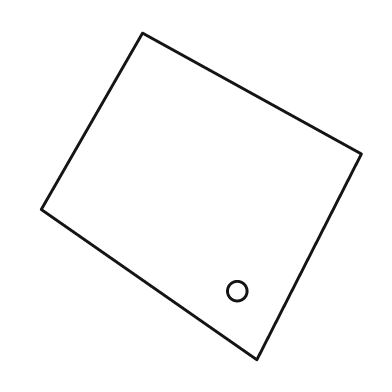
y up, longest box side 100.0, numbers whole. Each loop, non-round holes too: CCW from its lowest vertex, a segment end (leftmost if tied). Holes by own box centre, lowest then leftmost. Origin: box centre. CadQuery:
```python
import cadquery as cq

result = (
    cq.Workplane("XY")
    .moveTo(17.0, -50.0)
    .lineTo(49.0, 13.0)
    .lineTo(-18.0, 50.0)
    .lineTo(-49.0, -4.0)
    .close()
    .moveTo(11.0, -29.0)
    .circle(3.0)
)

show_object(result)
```